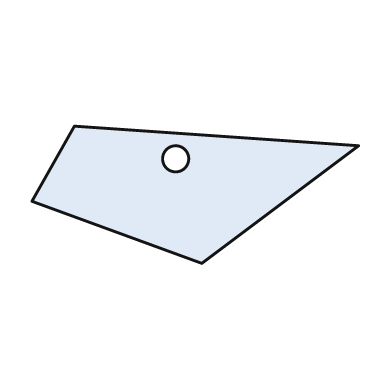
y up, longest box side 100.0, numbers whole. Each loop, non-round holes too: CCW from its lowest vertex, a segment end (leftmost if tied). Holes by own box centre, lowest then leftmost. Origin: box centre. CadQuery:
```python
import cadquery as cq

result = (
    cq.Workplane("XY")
    .moveTo(2.0, -21.0)
    .lineTo(50.0, 15.0)
    .lineTo(-37.0, 21.0)
    .lineTo(-50.0, -2.0)
    .close()
    .moveTo(-6.0, 11.0)
    .circle(4.0)
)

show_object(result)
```